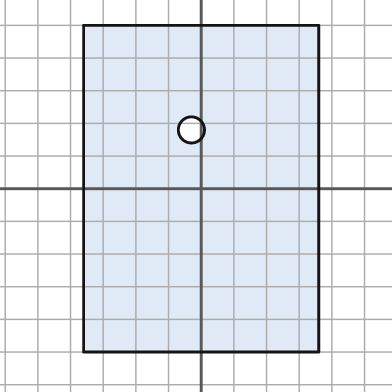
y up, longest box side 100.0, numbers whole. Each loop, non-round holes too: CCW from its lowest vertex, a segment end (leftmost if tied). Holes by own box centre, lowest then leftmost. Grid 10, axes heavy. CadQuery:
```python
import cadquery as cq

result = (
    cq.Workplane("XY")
    .moveTo(-36.0, -50.0)
    .lineTo(36.0, -50.0)
    .lineTo(36.0, 50.0)
    .lineTo(-36.0, 50.0)
    .close()
    .moveTo(-3.0, 18.0)
    .circle(4.0)
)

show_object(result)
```